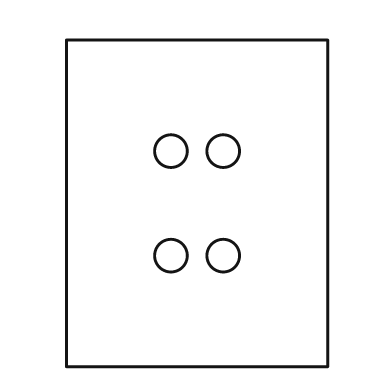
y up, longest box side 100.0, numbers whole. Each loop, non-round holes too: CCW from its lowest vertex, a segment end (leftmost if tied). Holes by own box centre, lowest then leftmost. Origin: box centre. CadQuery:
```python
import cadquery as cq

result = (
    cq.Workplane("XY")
    .moveTo(-40.0, -50.0)
    .lineTo(40.0, -50.0)
    .lineTo(40.0, 50.0)
    .lineTo(-40.0, 50.0)
    .close()
    .moveTo(-8.0, -16.0)
    .circle(5.0)
    .moveTo(8.0, -16.0)
    .circle(5.0)
    .moveTo(-8.0, 16.0)
    .circle(5.0)
    .moveTo(8.0, 16.0)
    .circle(5.0)
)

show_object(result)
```